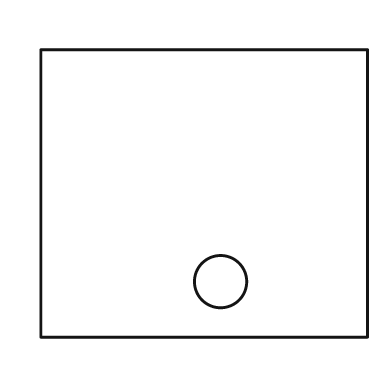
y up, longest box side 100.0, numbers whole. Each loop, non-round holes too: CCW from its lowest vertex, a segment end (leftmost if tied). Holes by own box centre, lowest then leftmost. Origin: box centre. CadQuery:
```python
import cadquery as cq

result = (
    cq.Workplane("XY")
    .moveTo(-50.0, -44.0)
    .lineTo(50.0, -44.0)
    .lineTo(50.0, 44.0)
    .lineTo(-50.0, 44.0)
    .close()
    .moveTo(5.0, -27.0)
    .circle(8.0)
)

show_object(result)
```